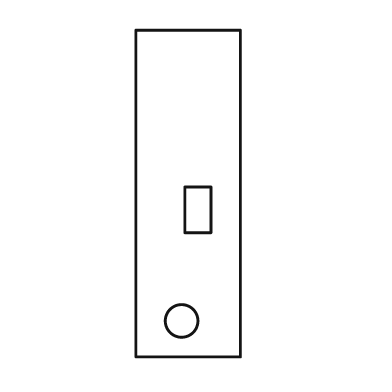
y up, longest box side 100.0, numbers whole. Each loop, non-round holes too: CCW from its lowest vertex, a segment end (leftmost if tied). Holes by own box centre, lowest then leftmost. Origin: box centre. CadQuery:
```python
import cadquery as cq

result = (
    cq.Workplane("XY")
    .moveTo(-16.0, -50.0)
    .lineTo(16.0, -50.0)
    .lineTo(16.0, 50.0)
    .lineTo(-16.0, 50.0)
    .close()
    .moveTo(-2.0, -39.0)
    .circle(5.0)
    .moveTo(-1.0, -12.0)
    .lineTo(7.0, -12.0)
    .lineTo(7.0, 2.0)
    .lineTo(-1.0, 2.0)
    .close()
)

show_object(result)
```